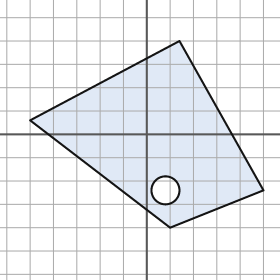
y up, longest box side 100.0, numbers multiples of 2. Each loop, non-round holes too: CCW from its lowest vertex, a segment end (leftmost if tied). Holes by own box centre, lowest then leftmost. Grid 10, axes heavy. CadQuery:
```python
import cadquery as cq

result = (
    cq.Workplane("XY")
    .moveTo(10.0, -40.0)
    .lineTo(50.0, -24.0)
    .lineTo(14.0, 40.0)
    .lineTo(-50.0, 6.0)
    .close()
    .moveTo(8.0, -24.0)
    .circle(6.0)
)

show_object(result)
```